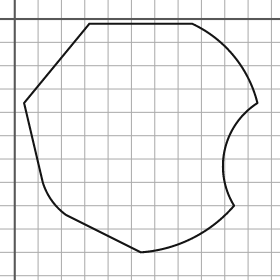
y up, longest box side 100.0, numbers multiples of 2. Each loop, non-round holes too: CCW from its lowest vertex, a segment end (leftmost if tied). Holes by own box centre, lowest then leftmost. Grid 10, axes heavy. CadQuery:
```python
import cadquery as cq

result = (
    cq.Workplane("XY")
    .moveTo(54.0, -100.0)
    .threePointArc((76.0, -94.0), (94.0, -80.0))
    .threePointArc((90.0, -56.0), (104.0, -36.0))
    .threePointArc((94.0, -16.0), (76.0, -2.0))
    .lineTo(32.0, -2.0)
    .lineTo(4.0, -36.0)
    .lineTo(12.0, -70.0)
    .threePointArc((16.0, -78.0), (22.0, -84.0))
    .close()
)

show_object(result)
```